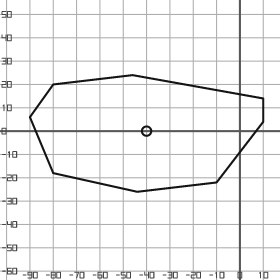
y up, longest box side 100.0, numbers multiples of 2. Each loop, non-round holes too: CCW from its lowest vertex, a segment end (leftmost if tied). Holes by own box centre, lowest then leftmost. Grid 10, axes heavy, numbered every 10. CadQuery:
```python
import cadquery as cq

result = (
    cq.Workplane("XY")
    .moveTo(-44.0, -26.0)
    .lineTo(-10.0, -22.0)
    .lineTo(10.0, 4.0)
    .lineTo(10.0, 14.0)
    .lineTo(-46.0, 24.0)
    .lineTo(-80.0, 20.0)
    .lineTo(-90.0, 6.0)
    .lineTo(-80.0, -18.0)
    .close()
    .moveTo(-40.0, 0.0)
    .circle(2.0)
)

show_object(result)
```